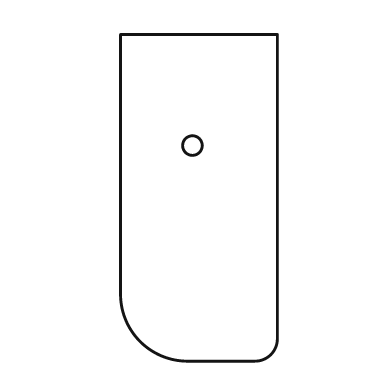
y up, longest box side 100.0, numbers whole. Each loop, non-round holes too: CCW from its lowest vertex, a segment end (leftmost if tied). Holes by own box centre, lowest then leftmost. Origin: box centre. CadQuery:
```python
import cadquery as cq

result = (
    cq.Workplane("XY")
    .moveTo(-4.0, -50.0)
    .lineTo(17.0, -50.0)
    .threePointArc((22.0, -48.0), (24.0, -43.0))
    .lineTo(24.0, 50.0)
    .lineTo(-24.0, 50.0)
    .lineTo(-24.0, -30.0)
    .threePointArc((-18.0, -44.0), (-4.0, -50.0))
    .close()
    .moveTo(-2.0, 16.0)
    .circle(3.0)
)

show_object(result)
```